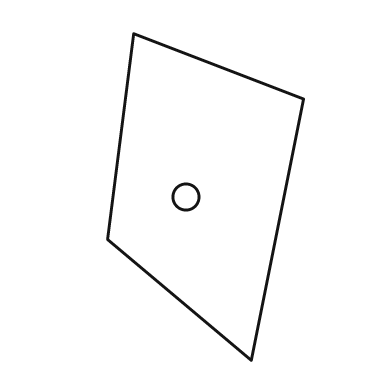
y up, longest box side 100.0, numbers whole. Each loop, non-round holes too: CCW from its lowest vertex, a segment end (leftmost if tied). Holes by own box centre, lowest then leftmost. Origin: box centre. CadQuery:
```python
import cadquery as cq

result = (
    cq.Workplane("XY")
    .moveTo(14.0, -50.0)
    .lineTo(30.0, 30.0)
    .lineTo(-22.0, 50.0)
    .lineTo(-30.0, -13.0)
    .close()
    .moveTo(-6.0, 0.0)
    .circle(4.0)
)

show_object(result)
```